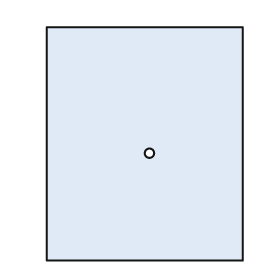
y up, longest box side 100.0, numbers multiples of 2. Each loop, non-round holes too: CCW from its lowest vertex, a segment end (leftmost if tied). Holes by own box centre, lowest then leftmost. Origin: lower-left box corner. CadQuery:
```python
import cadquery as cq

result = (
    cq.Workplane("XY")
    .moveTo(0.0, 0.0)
    .lineTo(84.0, 0.0)
    .lineTo(84.0, 100.0)
    .lineTo(0.0, 100.0)
    .close()
    .moveTo(44.0, 46.0)
    .circle(2.0)
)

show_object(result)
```